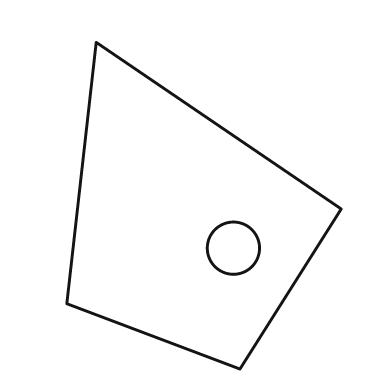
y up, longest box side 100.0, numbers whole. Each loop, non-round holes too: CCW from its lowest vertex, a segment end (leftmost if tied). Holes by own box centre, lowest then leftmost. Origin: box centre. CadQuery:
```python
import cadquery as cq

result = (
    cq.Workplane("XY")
    .moveTo(11.0, -50.0)
    .lineTo(42.0, -1.0)
    .lineTo(-33.0, 50.0)
    .lineTo(-42.0, -30.0)
    .close()
    .moveTo(9.0, -13.0)
    .circle(8.0)
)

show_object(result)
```